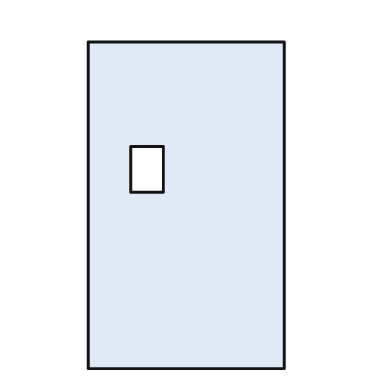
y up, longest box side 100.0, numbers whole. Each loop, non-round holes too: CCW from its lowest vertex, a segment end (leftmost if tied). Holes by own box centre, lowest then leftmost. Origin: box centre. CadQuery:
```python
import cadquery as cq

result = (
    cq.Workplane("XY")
    .moveTo(-30.0, -50.0)
    .lineTo(30.0, -50.0)
    .lineTo(30.0, 50.0)
    .lineTo(-30.0, 50.0)
    .close()
    .moveTo(-17.0, 4.0)
    .lineTo(-7.0, 4.0)
    .lineTo(-7.0, 18.0)
    .lineTo(-17.0, 18.0)
    .close()
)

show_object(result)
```